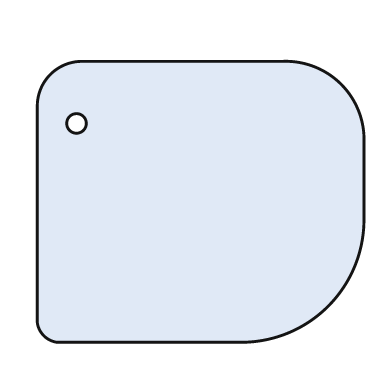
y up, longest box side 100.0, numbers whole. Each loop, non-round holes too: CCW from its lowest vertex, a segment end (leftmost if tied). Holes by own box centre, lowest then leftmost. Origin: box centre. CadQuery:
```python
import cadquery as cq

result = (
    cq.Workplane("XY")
    .moveTo(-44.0, -43.0)
    .lineTo(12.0, -43.0)
    .threePointArc((39.0, -32.0), (50.0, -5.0))
    .lineTo(50.0, 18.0)
    .threePointArc((43.0, 36.0), (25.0, 43.0))
    .lineTo(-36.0, 43.0)
    .threePointArc((-46.0, 39.0), (-50.0, 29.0))
    .lineTo(-50.0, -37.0)
    .threePointArc((-48.0, -41.0), (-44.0, -43.0))
    .close()
    .moveTo(-38.0, 24.0)
    .circle(3.0)
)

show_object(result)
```